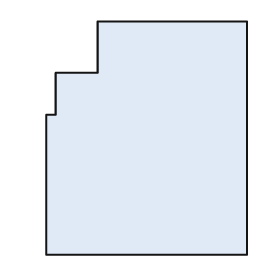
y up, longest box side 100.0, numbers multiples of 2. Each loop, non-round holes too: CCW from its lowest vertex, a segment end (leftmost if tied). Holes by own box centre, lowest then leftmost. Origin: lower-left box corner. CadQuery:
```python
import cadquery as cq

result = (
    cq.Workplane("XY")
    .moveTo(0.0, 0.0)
    .lineTo(86.0, 0.0)
    .lineTo(86.0, 100.0)
    .lineTo(22.0, 100.0)
    .lineTo(22.0, 78.0)
    .lineTo(4.0, 78.0)
    .lineTo(4.0, 60.0)
    .lineTo(0.0, 60.0)
    .close()
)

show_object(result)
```